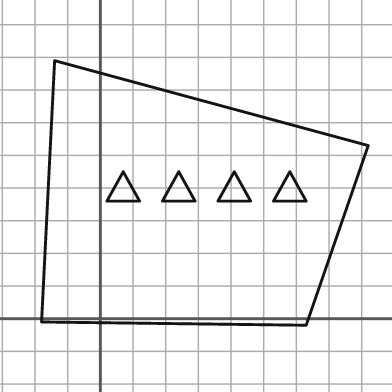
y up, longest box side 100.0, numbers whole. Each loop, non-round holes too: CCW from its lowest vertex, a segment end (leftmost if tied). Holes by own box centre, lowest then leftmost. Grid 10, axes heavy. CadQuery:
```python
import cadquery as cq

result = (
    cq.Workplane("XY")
    .moveTo(63.0, -2.0)
    .lineTo(82.0, 53.0)
    .lineTo(-14.0, 79.0)
    .lineTo(-18.0, -1.0)
    .close()
    .moveTo(2.0, 36.0)
    .lineTo(12.0, 36.0)
    .lineTo(7.0, 45.0)
    .close()
    .moveTo(19.0, 36.0)
    .lineTo(29.0, 36.0)
    .lineTo(24.0, 45.0)
    .close()
    .moveTo(36.0, 36.0)
    .lineTo(46.0, 36.0)
    .lineTo(41.0, 45.0)
    .close()
    .moveTo(53.0, 36.0)
    .lineTo(63.0, 36.0)
    .lineTo(58.0, 45.0)
    .close()
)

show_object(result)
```